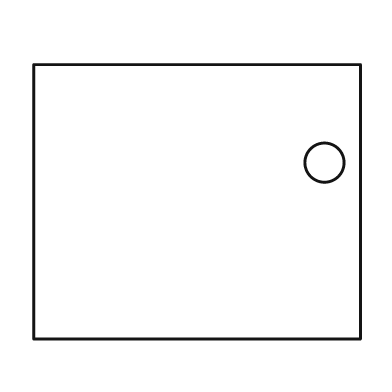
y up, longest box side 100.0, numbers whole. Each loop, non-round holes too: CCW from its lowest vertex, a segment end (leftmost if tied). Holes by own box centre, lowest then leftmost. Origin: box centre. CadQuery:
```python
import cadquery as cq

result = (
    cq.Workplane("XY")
    .moveTo(-50.0, -42.0)
    .lineTo(50.0, -42.0)
    .lineTo(50.0, 42.0)
    .lineTo(-50.0, 42.0)
    .close()
    .moveTo(39.0, 12.0)
    .circle(6.0)
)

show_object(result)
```